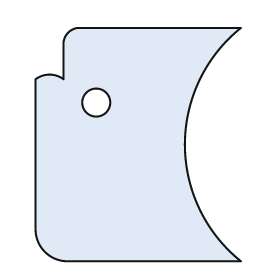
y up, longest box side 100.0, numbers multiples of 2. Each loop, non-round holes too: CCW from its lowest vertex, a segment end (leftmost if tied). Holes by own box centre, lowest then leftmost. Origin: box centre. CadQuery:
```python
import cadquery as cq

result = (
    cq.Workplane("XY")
    .moveTo(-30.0, -50.0)
    .lineTo(44.0, -50.0)
    .threePointArc((20.0, 0.0), (44.0, 50.0))
    .lineTo(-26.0, 50.0)
    .threePointArc((-30.0, 48.0), (-32.0, 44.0))
    .lineTo(-32.0, 28.0)
    .threePointArc((-38.0, 30.0), (-44.0, 28.0))
    .lineTo(-44.0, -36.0)
    .threePointArc((-40.0, -46.0), (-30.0, -50.0))
    .close()
    .moveTo(-18.0, 18.0)
    .circle(6.0)
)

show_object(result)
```